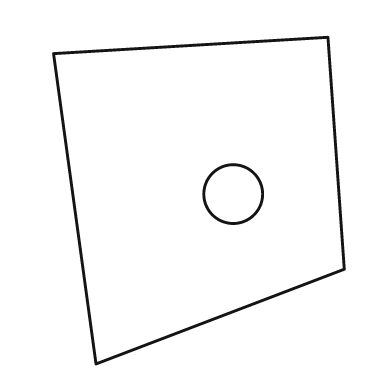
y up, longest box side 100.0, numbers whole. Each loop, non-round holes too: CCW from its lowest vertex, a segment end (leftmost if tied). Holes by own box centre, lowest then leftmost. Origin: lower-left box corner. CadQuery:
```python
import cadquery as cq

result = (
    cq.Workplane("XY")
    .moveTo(13.0, 0.0)
    .lineTo(89.0, 29.0)
    .lineTo(84.0, 100.0)
    .lineTo(0.0, 95.0)
    .close()
    .moveTo(55.0, 52.0)
    .circle(9.0)
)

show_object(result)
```